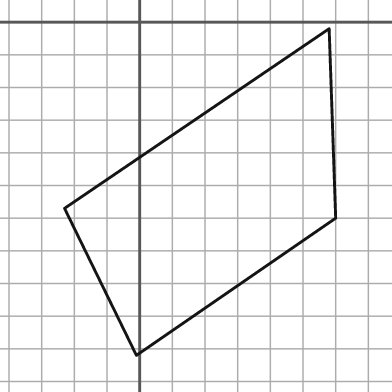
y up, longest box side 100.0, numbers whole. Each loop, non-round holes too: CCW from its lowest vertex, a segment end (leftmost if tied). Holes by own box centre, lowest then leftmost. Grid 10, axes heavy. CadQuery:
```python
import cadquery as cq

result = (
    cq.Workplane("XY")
    .moveTo(-1.0, -102.0)
    .lineTo(60.0, -60.0)
    .lineTo(58.0, -2.0)
    .lineTo(-23.0, -57.0)
    .close()
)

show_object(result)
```